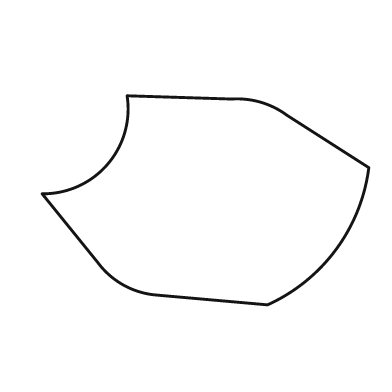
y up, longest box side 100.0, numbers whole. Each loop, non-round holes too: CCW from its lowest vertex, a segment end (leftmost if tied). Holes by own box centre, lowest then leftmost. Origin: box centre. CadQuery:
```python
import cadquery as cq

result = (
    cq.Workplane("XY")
    .moveTo(19.0, -32.0)
    .threePointArc((40.0, -15.0), (50.0, 10.0))
    .lineTo(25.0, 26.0)
    .threePointArc((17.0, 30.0), (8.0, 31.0))
    .lineTo(-24.0, 32.0)
    .threePointArc((-30.0, 11.0), (-50.0, 2.0))
    .lineTo(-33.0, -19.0)
    .threePointArc((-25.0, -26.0), (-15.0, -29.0))
    .close()
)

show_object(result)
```